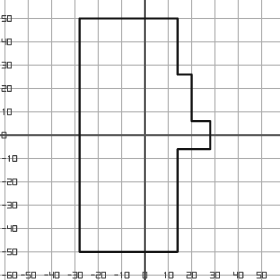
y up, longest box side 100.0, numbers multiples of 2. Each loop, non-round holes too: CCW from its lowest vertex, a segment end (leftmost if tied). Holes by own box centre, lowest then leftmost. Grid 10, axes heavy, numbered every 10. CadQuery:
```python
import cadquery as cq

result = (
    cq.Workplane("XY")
    .moveTo(-28.0, -50.0)
    .lineTo(14.0, -50.0)
    .lineTo(14.0, -6.0)
    .lineTo(28.0, -6.0)
    .lineTo(28.0, 6.0)
    .lineTo(20.0, 6.0)
    .lineTo(20.0, 26.0)
    .lineTo(14.0, 26.0)
    .lineTo(14.0, 50.0)
    .lineTo(-28.0, 50.0)
    .close()
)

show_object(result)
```